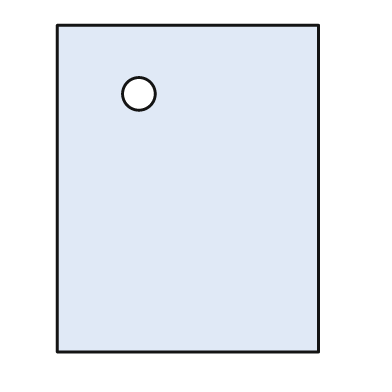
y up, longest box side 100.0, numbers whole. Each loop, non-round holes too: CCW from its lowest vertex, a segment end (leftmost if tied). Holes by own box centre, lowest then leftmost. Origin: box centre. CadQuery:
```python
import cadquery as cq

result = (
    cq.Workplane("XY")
    .moveTo(-40.0, -50.0)
    .lineTo(40.0, -50.0)
    .lineTo(40.0, 50.0)
    .lineTo(-40.0, 50.0)
    .close()
    .moveTo(-15.0, 29.0)
    .circle(5.0)
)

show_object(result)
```